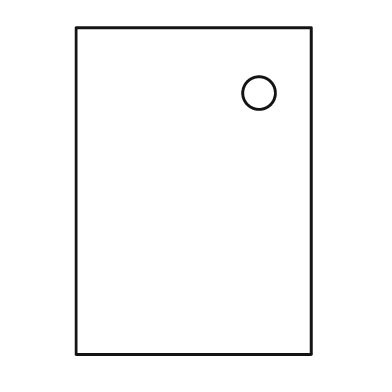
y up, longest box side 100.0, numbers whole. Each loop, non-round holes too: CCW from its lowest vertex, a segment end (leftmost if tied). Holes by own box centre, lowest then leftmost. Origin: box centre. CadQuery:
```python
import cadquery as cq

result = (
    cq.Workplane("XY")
    .moveTo(-36.0, -50.0)
    .lineTo(36.0, -50.0)
    .lineTo(36.0, 50.0)
    .lineTo(-36.0, 50.0)
    .close()
    .moveTo(20.0, 30.0)
    .circle(5.0)
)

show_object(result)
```